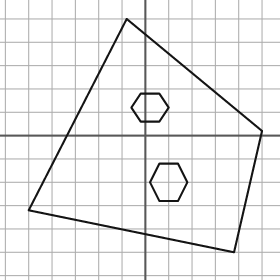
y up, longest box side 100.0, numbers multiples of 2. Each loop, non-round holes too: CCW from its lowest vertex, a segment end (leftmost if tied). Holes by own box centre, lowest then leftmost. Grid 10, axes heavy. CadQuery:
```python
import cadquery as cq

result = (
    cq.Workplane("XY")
    .moveTo(38.0, -50.0)
    .lineTo(50.0, 2.0)
    .lineTo(-8.0, 50.0)
    .lineTo(-50.0, -32.0)
    .close()
    .moveTo(6.0, -28.0)
    .lineTo(14.0, -28.0)
    .lineTo(18.0, -20.0)
    .lineTo(14.0, -12.0)
    .lineTo(6.0, -12.0)
    .lineTo(2.0, -20.0)
    .close()
    .moveTo(-2.0, 6.0)
    .lineTo(6.0, 6.0)
    .lineTo(10.0, 12.0)
    .lineTo(6.0, 18.0)
    .lineTo(-2.0, 18.0)
    .lineTo(-6.0, 12.0)
    .close()
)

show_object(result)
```